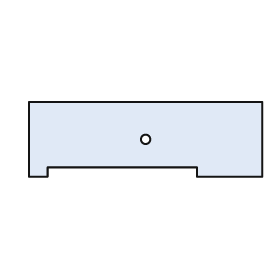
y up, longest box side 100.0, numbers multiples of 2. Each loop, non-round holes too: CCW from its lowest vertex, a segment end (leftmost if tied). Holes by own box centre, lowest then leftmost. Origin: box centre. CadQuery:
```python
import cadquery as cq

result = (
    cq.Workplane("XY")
    .moveTo(-50.0, -16.0)
    .lineTo(-42.0, -16.0)
    .lineTo(-42.0, -12.0)
    .lineTo(22.0, -12.0)
    .lineTo(22.0, -16.0)
    .lineTo(50.0, -16.0)
    .lineTo(50.0, 16.0)
    .lineTo(-50.0, 16.0)
    .close()
    .moveTo(0.0, 0.0)
    .circle(2.0)
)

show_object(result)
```